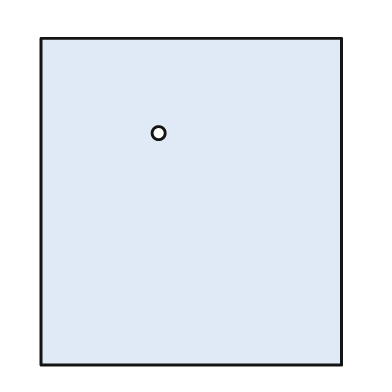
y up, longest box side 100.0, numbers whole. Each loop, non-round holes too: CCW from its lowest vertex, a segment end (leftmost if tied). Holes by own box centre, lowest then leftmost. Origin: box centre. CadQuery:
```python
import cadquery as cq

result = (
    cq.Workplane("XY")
    .moveTo(-46.0, -50.0)
    .lineTo(46.0, -50.0)
    .lineTo(46.0, 50.0)
    .lineTo(-46.0, 50.0)
    .close()
    .moveTo(-10.0, 21.0)
    .circle(2.0)
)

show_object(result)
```